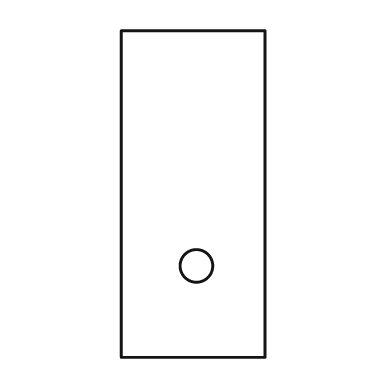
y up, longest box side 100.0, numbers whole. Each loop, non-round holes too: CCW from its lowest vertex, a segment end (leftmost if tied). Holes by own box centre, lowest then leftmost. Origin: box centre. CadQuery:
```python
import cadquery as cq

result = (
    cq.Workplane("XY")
    .moveTo(-22.0, -50.0)
    .lineTo(22.0, -50.0)
    .lineTo(22.0, 50.0)
    .lineTo(-22.0, 50.0)
    .close()
    .moveTo(1.0, -22.0)
    .circle(5.0)
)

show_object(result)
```